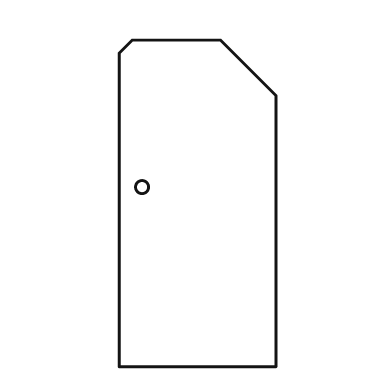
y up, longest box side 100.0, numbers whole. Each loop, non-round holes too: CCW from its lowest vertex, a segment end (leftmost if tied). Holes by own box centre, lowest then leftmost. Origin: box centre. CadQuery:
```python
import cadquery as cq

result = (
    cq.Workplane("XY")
    .moveTo(-24.0, -50.0)
    .lineTo(24.0, -50.0)
    .lineTo(24.0, 33.0)
    .lineTo(7.0, 50.0)
    .lineTo(-20.0, 50.0)
    .lineTo(-24.0, 46.0)
    .close()
    .moveTo(-17.0, 5.0)
    .circle(2.0)
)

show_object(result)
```